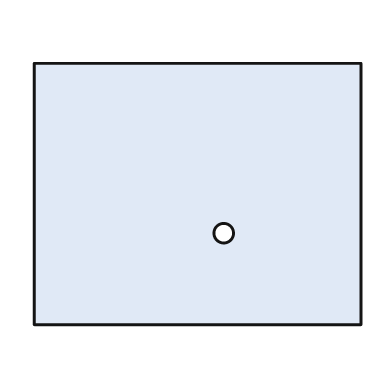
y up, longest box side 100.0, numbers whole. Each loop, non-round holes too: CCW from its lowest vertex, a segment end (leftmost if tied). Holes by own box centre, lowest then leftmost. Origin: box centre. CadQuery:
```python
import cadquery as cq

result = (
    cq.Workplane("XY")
    .moveTo(-50.0, -40.0)
    .lineTo(50.0, -40.0)
    .lineTo(50.0, 40.0)
    .lineTo(-50.0, 40.0)
    .close()
    .moveTo(8.0, -12.0)
    .circle(3.0)
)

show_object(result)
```